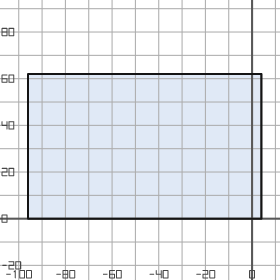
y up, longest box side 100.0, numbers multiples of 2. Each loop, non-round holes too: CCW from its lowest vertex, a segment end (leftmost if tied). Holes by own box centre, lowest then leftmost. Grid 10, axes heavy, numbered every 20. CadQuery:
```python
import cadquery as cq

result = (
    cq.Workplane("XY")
    .moveTo(-96.0, 0.0)
    .lineTo(4.0, 0.0)
    .lineTo(4.0, 62.0)
    .lineTo(-96.0, 62.0)
    .close()
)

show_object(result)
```